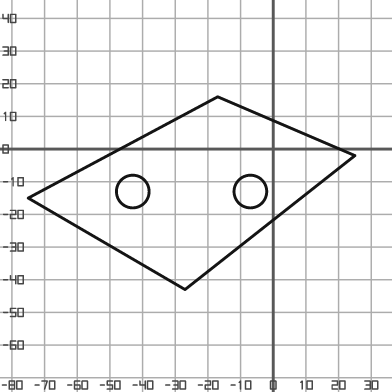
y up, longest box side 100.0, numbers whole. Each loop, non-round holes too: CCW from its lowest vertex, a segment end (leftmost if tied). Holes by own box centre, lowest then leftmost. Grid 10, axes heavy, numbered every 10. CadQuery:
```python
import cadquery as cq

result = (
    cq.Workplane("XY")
    .moveTo(-27.0, -43.0)
    .lineTo(25.0, -2.0)
    .lineTo(-17.0, 16.0)
    .lineTo(-75.0, -15.0)
    .close()
    .moveTo(-43.0, -13.0)
    .circle(5.0)
    .moveTo(-7.0, -13.0)
    .circle(5.0)
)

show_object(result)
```